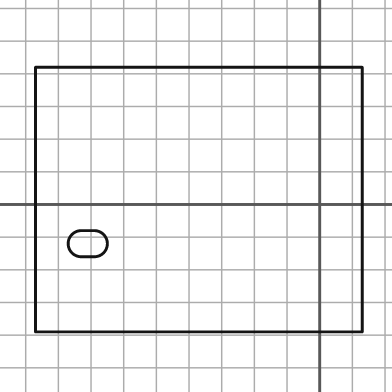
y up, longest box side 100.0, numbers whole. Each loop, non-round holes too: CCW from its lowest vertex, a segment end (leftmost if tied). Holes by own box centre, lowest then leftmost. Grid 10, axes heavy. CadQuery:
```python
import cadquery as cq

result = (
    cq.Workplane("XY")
    .moveTo(-87.0, -39.0)
    .lineTo(13.0, -39.0)
    .lineTo(13.0, 42.0)
    .lineTo(-87.0, 42.0)
    .close()
    .moveTo(-73.0, -16.0)
    .lineTo(-69.0, -16.0)
    .threePointArc((-65.0, -12.0), (-69.0, -8.0))
    .lineTo(-73.0, -8.0)
    .threePointArc((-77.0, -12.0), (-73.0, -16.0))
    .close()
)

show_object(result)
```